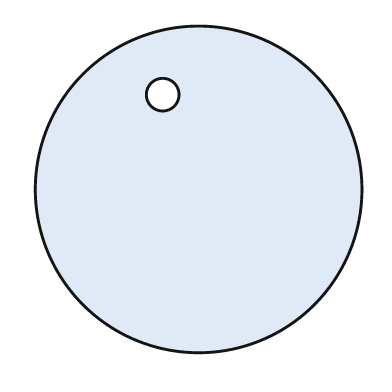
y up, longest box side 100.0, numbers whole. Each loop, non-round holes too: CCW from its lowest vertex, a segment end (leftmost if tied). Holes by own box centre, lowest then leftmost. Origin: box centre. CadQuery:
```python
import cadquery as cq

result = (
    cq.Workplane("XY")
    .moveTo(0.0, 0.0)
    .circle(50.0)
    .moveTo(-11.0, 29.0)
    .circle(5.0)
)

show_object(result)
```